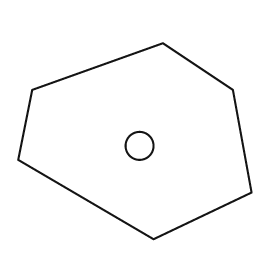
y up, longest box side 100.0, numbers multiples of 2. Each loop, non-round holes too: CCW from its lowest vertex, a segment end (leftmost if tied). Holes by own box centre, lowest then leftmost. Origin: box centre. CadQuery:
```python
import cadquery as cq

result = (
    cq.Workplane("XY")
    .moveTo(8.0, -42.0)
    .lineTo(50.0, -22.0)
    .lineTo(42.0, 22.0)
    .lineTo(12.0, 42.0)
    .lineTo(-44.0, 22.0)
    .lineTo(-50.0, -8.0)
    .close()
    .moveTo(2.0, -2.0)
    .circle(6.0)
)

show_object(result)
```